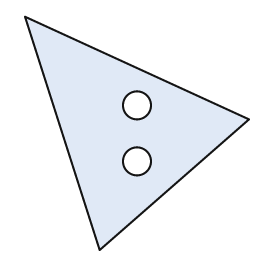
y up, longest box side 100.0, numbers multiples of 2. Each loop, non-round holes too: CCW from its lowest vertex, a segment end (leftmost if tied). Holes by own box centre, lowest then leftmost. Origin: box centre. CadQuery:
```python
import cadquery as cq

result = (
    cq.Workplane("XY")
    .moveTo(-16.0, -50.0)
    .lineTo(48.0, 6.0)
    .lineTo(-48.0, 50.0)
    .close()
    .moveTo(0.0, -12.0)
    .circle(6.0)
    .moveTo(0.0, 12.0)
    .circle(6.0)
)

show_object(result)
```